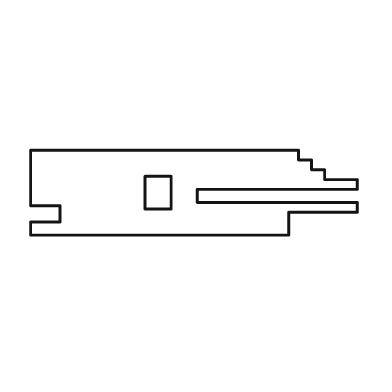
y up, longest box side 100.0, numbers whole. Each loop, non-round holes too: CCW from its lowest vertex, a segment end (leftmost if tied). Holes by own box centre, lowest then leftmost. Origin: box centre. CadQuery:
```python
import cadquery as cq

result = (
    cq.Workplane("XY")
    .moveTo(-50.0, -13.0)
    .lineTo(29.0, -13.0)
    .lineTo(29.0, -6.0)
    .lineTo(50.0, -6.0)
    .lineTo(50.0, -3.0)
    .lineTo(1.0, -3.0)
    .lineTo(1.0, 1.0)
    .lineTo(50.0, 1.0)
    .lineTo(50.0, 4.0)
    .lineTo(40.0, 4.0)
    .lineTo(40.0, 7.0)
    .lineTo(36.0, 7.0)
    .lineTo(36.0, 10.0)
    .lineTo(32.0, 10.0)
    .lineTo(32.0, 13.0)
    .lineTo(-50.0, 13.0)
    .lineTo(-50.0, -4.0)
    .lineTo(-41.0, -4.0)
    .lineTo(-41.0, -9.0)
    .lineTo(-50.0, -9.0)
    .close()
    .moveTo(-15.0, -5.0)
    .lineTo(-7.0, -5.0)
    .lineTo(-7.0, 5.0)
    .lineTo(-15.0, 5.0)
    .close()
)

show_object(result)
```